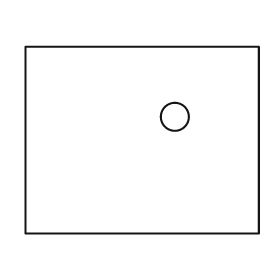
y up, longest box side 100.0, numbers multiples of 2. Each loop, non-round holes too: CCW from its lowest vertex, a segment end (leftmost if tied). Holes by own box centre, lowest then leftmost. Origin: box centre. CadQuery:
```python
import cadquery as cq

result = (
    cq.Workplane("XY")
    .moveTo(-50.0, -40.0)
    .lineTo(50.0, -40.0)
    .lineTo(50.0, 40.0)
    .lineTo(-50.0, 40.0)
    .close()
    .moveTo(14.0, 10.0)
    .circle(6.0)
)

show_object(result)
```